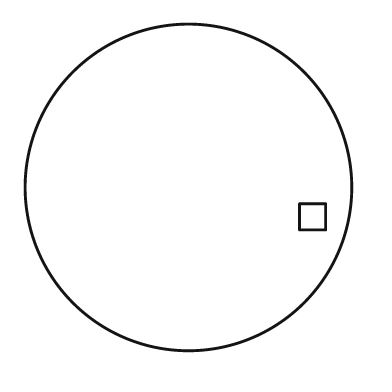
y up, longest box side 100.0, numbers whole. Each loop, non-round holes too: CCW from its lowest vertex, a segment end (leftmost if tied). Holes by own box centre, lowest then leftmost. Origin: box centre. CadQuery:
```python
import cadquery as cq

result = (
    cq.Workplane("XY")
    .moveTo(0.0, 0.0)
    .circle(50.0)
    .moveTo(34.0, -13.0)
    .lineTo(42.0, -13.0)
    .lineTo(42.0, -5.0)
    .lineTo(34.0, -5.0)
    .close()
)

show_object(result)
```